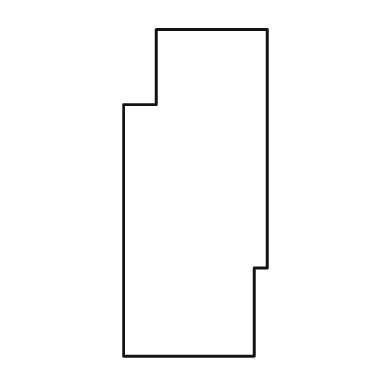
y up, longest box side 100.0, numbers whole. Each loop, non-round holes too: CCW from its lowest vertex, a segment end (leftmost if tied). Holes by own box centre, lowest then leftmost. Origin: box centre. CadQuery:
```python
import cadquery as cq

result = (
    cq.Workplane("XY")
    .moveTo(-22.0, -50.0)
    .lineTo(18.0, -50.0)
    .lineTo(18.0, -23.0)
    .lineTo(22.0, -23.0)
    .lineTo(22.0, 50.0)
    .lineTo(-12.0, 50.0)
    .lineTo(-12.0, 27.0)
    .lineTo(-22.0, 27.0)
    .close()
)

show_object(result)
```